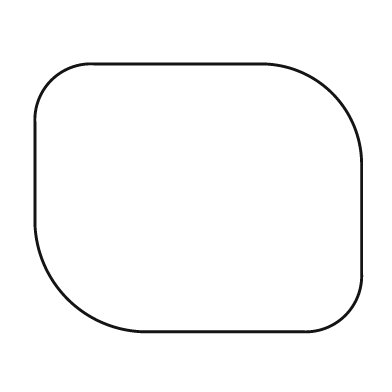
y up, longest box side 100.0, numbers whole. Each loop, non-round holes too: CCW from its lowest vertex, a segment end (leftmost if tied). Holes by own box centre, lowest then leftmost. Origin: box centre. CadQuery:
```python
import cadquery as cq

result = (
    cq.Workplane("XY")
    .moveTo(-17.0, -41.0)
    .lineTo(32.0, -41.0)
    .threePointArc((45.0, -36.0), (50.0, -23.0))
    .lineTo(50.0, 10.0)
    .threePointArc((41.0, 32.0), (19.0, 41.0))
    .lineTo(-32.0, 41.0)
    .threePointArc((-45.0, 36.0), (-50.0, 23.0))
    .lineTo(-50.0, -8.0)
    .threePointArc((-40.0, -31.0), (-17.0, -41.0))
    .close()
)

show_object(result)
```